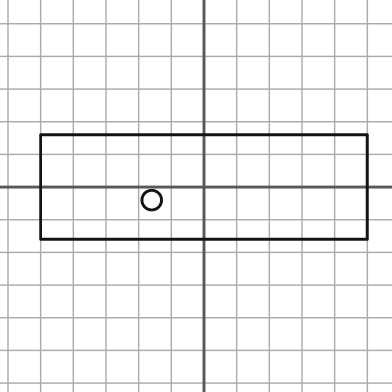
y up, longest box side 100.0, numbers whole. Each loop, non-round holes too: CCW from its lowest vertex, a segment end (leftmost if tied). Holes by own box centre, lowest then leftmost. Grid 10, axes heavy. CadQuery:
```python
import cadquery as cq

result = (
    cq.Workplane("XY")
    .moveTo(-50.0, -16.0)
    .lineTo(50.0, -16.0)
    .lineTo(50.0, 16.0)
    .lineTo(-50.0, 16.0)
    .close()
    .moveTo(-16.0, -4.0)
    .circle(3.0)
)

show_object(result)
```